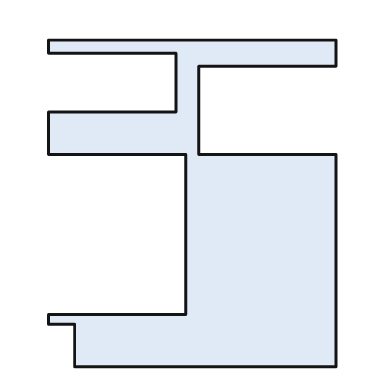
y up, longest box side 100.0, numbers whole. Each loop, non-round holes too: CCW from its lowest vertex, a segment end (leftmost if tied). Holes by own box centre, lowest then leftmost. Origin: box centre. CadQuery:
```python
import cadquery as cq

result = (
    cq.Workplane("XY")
    .moveTo(-36.0, -50.0)
    .lineTo(44.0, -50.0)
    .lineTo(44.0, 15.0)
    .lineTo(2.0, 15.0)
    .lineTo(2.0, 42.0)
    .lineTo(44.0, 42.0)
    .lineTo(44.0, 50.0)
    .lineTo(-44.0, 50.0)
    .lineTo(-44.0, 46.0)
    .lineTo(-5.0, 46.0)
    .lineTo(-5.0, 28.0)
    .lineTo(-44.0, 28.0)
    .lineTo(-44.0, 15.0)
    .lineTo(-2.0, 15.0)
    .lineTo(-2.0, -34.0)
    .lineTo(-44.0, -34.0)
    .lineTo(-44.0, -37.0)
    .lineTo(-36.0, -37.0)
    .close()
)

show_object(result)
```